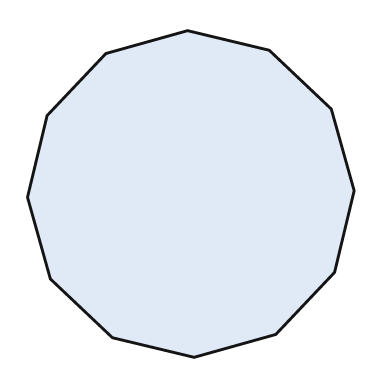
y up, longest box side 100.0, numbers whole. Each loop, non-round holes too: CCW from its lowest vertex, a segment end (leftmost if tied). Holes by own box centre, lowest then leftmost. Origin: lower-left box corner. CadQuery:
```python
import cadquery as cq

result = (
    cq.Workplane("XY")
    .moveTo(51.0, 0.0)
    .lineTo(76.0, 7.0)
    .lineTo(94.0, 26.0)
    .lineTo(100.0, 51.0)
    .lineTo(93.0, 76.0)
    .lineTo(74.0, 94.0)
    .lineTo(49.0, 100.0)
    .lineTo(24.0, 93.0)
    .lineTo(6.0, 74.0)
    .lineTo(0.0, 49.0)
    .lineTo(7.0, 24.0)
    .lineTo(26.0, 6.0)
    .close()
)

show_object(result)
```